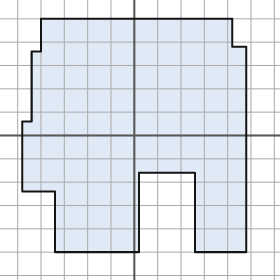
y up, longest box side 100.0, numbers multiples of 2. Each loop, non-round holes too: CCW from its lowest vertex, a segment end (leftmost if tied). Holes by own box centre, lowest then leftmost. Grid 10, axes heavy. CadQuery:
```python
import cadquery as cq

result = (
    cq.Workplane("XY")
    .moveTo(-34.0, -50.0)
    .lineTo(2.0, -50.0)
    .lineTo(2.0, -16.0)
    .lineTo(26.0, -16.0)
    .lineTo(26.0, -50.0)
    .lineTo(48.0, -50.0)
    .lineTo(48.0, 38.0)
    .lineTo(42.0, 38.0)
    .lineTo(42.0, 50.0)
    .lineTo(-40.0, 50.0)
    .lineTo(-40.0, 36.0)
    .lineTo(-44.0, 36.0)
    .lineTo(-44.0, 6.0)
    .lineTo(-48.0, 6.0)
    .lineTo(-48.0, -24.0)
    .lineTo(-34.0, -24.0)
    .close()
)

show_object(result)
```